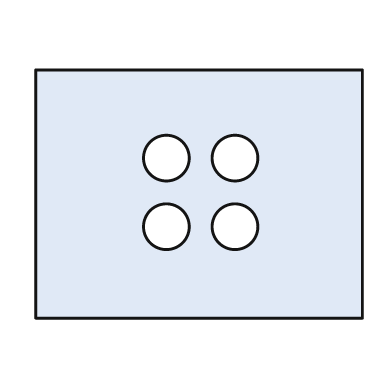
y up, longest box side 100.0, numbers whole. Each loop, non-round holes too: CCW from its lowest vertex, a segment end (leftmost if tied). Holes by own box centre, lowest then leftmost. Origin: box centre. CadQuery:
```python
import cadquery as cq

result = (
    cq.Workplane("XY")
    .moveTo(-50.0, -38.0)
    .lineTo(50.0, -38.0)
    .lineTo(50.0, 38.0)
    .lineTo(-50.0, 38.0)
    .close()
    .moveTo(-10.0, -10.0)
    .circle(7.0)
    .moveTo(11.0, -10.0)
    .circle(7.0)
    .moveTo(-10.0, 11.0)
    .circle(7.0)
    .moveTo(11.0, 11.0)
    .circle(7.0)
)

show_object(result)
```